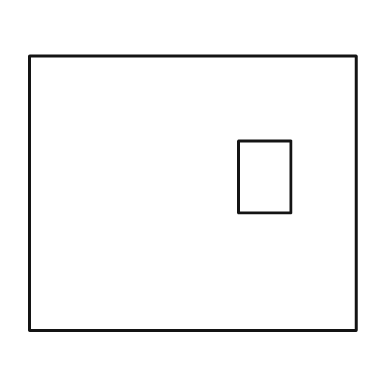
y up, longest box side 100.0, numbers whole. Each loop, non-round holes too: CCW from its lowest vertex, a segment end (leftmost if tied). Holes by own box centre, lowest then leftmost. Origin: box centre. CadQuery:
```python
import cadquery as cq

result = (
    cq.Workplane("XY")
    .moveTo(-50.0, -42.0)
    .lineTo(50.0, -42.0)
    .lineTo(50.0, 42.0)
    .lineTo(-50.0, 42.0)
    .close()
    .moveTo(14.0, -6.0)
    .lineTo(30.0, -6.0)
    .lineTo(30.0, 16.0)
    .lineTo(14.0, 16.0)
    .close()
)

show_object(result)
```